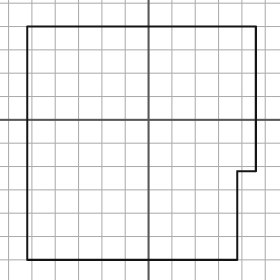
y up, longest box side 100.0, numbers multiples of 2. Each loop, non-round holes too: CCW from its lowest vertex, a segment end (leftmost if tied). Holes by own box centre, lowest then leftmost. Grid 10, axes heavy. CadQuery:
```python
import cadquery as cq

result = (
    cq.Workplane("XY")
    .moveTo(-52.0, -60.0)
    .lineTo(38.0, -60.0)
    .lineTo(38.0, -22.0)
    .lineTo(46.0, -22.0)
    .lineTo(46.0, 40.0)
    .lineTo(-52.0, 40.0)
    .close()
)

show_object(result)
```